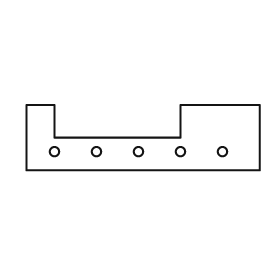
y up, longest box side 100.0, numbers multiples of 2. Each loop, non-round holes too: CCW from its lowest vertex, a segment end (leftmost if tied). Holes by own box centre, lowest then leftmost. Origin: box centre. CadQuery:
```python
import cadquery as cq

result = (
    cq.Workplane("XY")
    .moveTo(-50.0, -14.0)
    .lineTo(50.0, -14.0)
    .lineTo(50.0, 14.0)
    .lineTo(16.0, 14.0)
    .lineTo(16.0, 0.0)
    .lineTo(-38.0, 0.0)
    .lineTo(-38.0, 14.0)
    .lineTo(-50.0, 14.0)
    .close()
    .moveTo(-38.0, -6.0)
    .circle(2.0)
    .moveTo(-20.0, -6.0)
    .circle(2.0)
    .moveTo(-2.0, -6.0)
    .circle(2.0)
    .moveTo(16.0, -6.0)
    .circle(2.0)
    .moveTo(34.0, -6.0)
    .circle(2.0)
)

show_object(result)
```